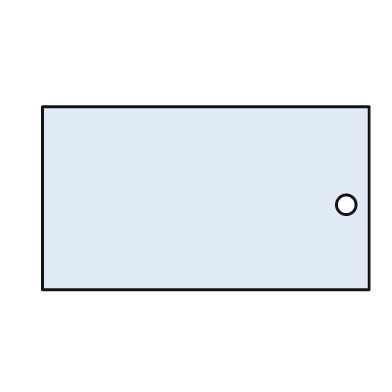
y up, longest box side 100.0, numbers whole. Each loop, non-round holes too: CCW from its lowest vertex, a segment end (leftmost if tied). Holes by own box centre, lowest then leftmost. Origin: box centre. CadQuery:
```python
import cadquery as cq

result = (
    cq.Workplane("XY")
    .moveTo(-50.0, -28.0)
    .lineTo(50.0, -28.0)
    .lineTo(50.0, 28.0)
    .lineTo(-50.0, 28.0)
    .close()
    .moveTo(43.0, -2.0)
    .circle(3.0)
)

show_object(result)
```